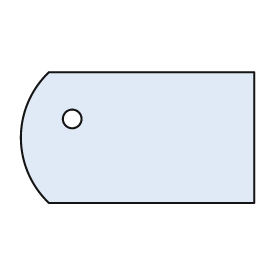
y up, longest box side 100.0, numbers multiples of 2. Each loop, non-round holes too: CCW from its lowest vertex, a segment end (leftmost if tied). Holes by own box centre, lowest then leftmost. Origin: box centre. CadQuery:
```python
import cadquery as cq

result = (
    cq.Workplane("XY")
    .moveTo(-38.0, -28.0)
    .lineTo(50.0, -28.0)
    .lineTo(50.0, 28.0)
    .lineTo(-38.0, 28.0)
    .threePointArc((-50.0, 0.0), (-38.0, -28.0))
    .close()
    .moveTo(-28.0, 8.0)
    .circle(4.0)
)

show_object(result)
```